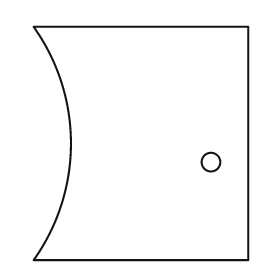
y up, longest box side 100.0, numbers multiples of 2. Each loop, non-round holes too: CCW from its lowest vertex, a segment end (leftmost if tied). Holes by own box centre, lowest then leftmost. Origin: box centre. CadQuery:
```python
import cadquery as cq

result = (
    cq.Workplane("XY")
    .moveTo(-46.0, -50.0)
    .lineTo(46.0, -50.0)
    .lineTo(46.0, 50.0)
    .lineTo(-46.0, 50.0)
    .threePointArc((-30.0, 0.0), (-46.0, -50.0))
    .close()
    .moveTo(30.0, -8.0)
    .circle(4.0)
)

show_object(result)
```